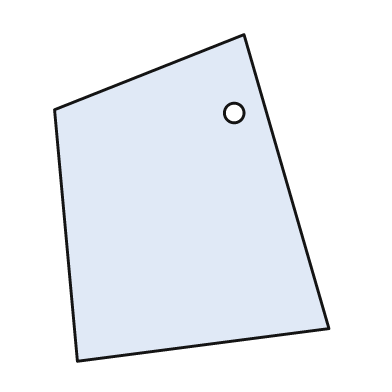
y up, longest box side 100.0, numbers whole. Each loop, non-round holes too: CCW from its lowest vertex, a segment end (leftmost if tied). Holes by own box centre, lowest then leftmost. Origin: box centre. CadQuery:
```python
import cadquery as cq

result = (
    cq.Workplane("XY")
    .moveTo(-35.0, -50.0)
    .lineTo(42.0, -40.0)
    .lineTo(16.0, 50.0)
    .lineTo(-42.0, 27.0)
    .close()
    .moveTo(13.0, 26.0)
    .circle(3.0)
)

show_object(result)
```